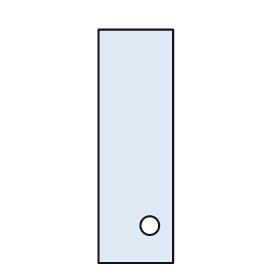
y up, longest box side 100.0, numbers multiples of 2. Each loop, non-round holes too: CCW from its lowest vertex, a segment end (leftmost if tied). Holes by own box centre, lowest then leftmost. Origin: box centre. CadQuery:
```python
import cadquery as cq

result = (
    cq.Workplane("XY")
    .moveTo(-16.0, -50.0)
    .lineTo(16.0, -50.0)
    .lineTo(16.0, 50.0)
    .lineTo(-16.0, 50.0)
    .close()
    .moveTo(6.0, -34.0)
    .circle(4.0)
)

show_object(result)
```